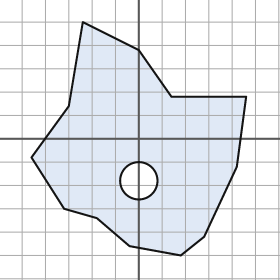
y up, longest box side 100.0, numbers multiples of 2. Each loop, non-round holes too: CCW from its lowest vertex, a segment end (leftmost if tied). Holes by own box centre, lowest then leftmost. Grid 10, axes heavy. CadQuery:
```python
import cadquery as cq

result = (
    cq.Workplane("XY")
    .moveTo(18.0, -50.0)
    .lineTo(28.0, -42.0)
    .lineTo(42.0, -12.0)
    .lineTo(46.0, 18.0)
    .lineTo(14.0, 18.0)
    .lineTo(0.0, 38.0)
    .lineTo(-24.0, 50.0)
    .lineTo(-30.0, 14.0)
    .lineTo(-46.0, -8.0)
    .lineTo(-32.0, -30.0)
    .lineTo(-18.0, -34.0)
    .lineTo(-4.0, -46.0)
    .close()
    .moveTo(0.0, -18.0)
    .circle(8.0)
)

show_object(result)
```